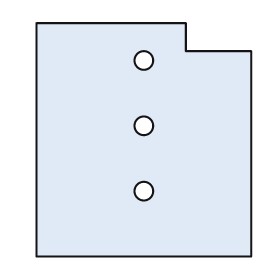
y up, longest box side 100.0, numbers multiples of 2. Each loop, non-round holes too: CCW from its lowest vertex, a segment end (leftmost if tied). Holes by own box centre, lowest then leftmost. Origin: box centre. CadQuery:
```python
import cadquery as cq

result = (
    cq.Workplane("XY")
    .moveTo(-46.0, -50.0)
    .lineTo(46.0, -50.0)
    .lineTo(46.0, 38.0)
    .lineTo(18.0, 38.0)
    .lineTo(18.0, 50.0)
    .lineTo(-46.0, 50.0)
    .close()
    .moveTo(0.0, -22.0)
    .circle(4.0)
    .moveTo(0.0, 6.0)
    .circle(4.0)
    .moveTo(0.0, 34.0)
    .circle(4.0)
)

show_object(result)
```